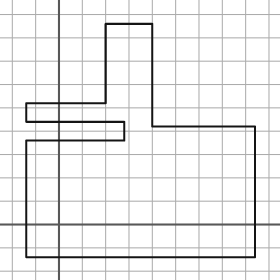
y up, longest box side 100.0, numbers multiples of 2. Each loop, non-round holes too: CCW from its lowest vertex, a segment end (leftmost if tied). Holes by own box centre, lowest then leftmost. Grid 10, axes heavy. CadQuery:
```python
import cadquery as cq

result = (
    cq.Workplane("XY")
    .moveTo(-14.0, -14.0)
    .lineTo(84.0, -14.0)
    .lineTo(84.0, 42.0)
    .lineTo(40.0, 42.0)
    .lineTo(40.0, 86.0)
    .lineTo(20.0, 86.0)
    .lineTo(20.0, 52.0)
    .lineTo(-14.0, 52.0)
    .lineTo(-14.0, 44.0)
    .lineTo(28.0, 44.0)
    .lineTo(28.0, 36.0)
    .lineTo(-14.0, 36.0)
    .close()
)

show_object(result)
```